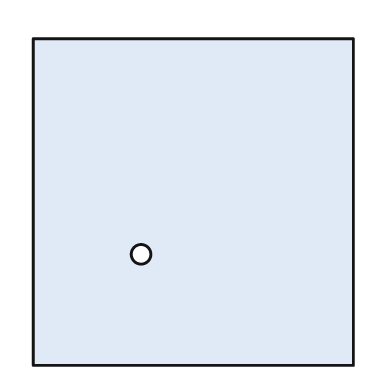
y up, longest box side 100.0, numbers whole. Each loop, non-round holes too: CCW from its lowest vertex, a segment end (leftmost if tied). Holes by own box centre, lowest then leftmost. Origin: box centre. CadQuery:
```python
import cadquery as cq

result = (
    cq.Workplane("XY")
    .moveTo(-49.0, -50.0)
    .lineTo(49.0, -50.0)
    .lineTo(49.0, 50.0)
    .lineTo(-49.0, 50.0)
    .close()
    .moveTo(-16.0, -16.0)
    .circle(3.0)
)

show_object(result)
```